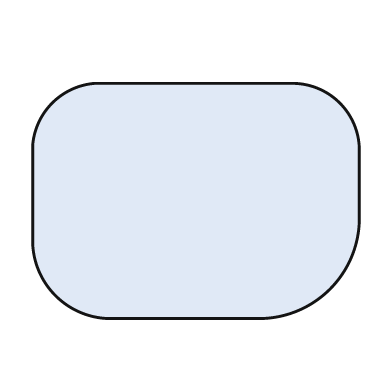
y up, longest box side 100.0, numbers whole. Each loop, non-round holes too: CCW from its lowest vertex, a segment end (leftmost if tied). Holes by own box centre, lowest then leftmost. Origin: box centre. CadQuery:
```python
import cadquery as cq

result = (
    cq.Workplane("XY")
    .moveTo(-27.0, -36.0)
    .lineTo(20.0, -36.0)
    .threePointArc((41.0, -27.0), (50.0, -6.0))
    .lineTo(50.0, 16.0)
    .threePointArc((44.0, 30.0), (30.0, 36.0))
    .lineTo(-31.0, 36.0)
    .threePointArc((-44.0, 30.0), (-50.0, 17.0))
    .lineTo(-50.0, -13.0)
    .threePointArc((-43.0, -29.0), (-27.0, -36.0))
    .close()
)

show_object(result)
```